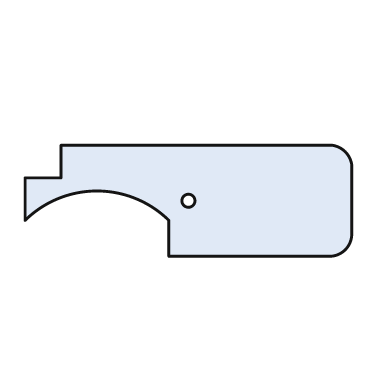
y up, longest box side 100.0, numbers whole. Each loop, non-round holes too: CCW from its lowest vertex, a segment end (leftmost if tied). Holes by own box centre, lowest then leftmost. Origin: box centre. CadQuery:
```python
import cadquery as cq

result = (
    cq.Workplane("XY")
    .moveTo(-6.0, -17.0)
    .lineTo(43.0, -17.0)
    .threePointArc((48.0, -15.0), (50.0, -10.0))
    .lineTo(50.0, 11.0)
    .threePointArc((48.0, 15.0), (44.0, 17.0))
    .lineTo(-39.0, 17.0)
    .lineTo(-39.0, 7.0)
    .lineTo(-50.0, 7.0)
    .lineTo(-50.0, -6.0)
    .threePointArc((-28.0, 3.0), (-6.0, -6.0))
    .close()
    .moveTo(0.0, 0.0)
    .circle(2.0)
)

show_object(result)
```